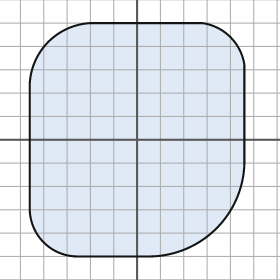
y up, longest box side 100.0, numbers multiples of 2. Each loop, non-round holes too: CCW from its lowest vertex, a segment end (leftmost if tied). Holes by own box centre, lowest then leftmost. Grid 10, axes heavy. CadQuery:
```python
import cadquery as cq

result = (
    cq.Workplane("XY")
    .moveTo(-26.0, -50.0)
    .lineTo(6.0, -50.0)
    .threePointArc((34.0, -38.0), (46.0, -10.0))
    .lineTo(46.0, 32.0)
    .threePointArc((40.0, 44.0), (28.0, 50.0))
    .lineTo(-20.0, 50.0)
    .threePointArc((-38.0, 42.0), (-46.0, 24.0))
    .lineTo(-46.0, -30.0)
    .threePointArc((-40.0, -44.0), (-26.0, -50.0))
    .close()
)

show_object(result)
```